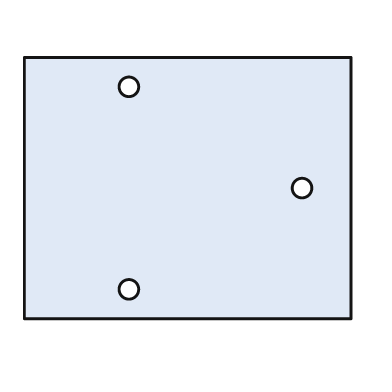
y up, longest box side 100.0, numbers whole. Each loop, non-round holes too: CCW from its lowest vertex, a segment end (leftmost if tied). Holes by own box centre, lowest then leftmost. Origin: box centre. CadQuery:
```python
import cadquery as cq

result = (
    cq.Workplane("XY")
    .moveTo(-50.0, -40.0)
    .lineTo(50.0, -40.0)
    .lineTo(50.0, 40.0)
    .lineTo(-50.0, 40.0)
    .close()
    .moveTo(-18.0, -31.0)
    .circle(3.0)
    .moveTo(35.0, 0.0)
    .circle(3.0)
    .moveTo(-18.0, 31.0)
    .circle(3.0)
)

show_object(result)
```